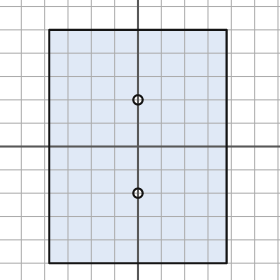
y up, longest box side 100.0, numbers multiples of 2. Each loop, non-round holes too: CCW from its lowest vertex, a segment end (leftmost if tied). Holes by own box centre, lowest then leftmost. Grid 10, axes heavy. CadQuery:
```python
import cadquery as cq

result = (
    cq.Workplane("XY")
    .moveTo(-38.0, -50.0)
    .lineTo(38.0, -50.0)
    .lineTo(38.0, 50.0)
    .lineTo(-38.0, 50.0)
    .close()
    .moveTo(0.0, -20.0)
    .circle(2.0)
    .moveTo(0.0, 20.0)
    .circle(2.0)
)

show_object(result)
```